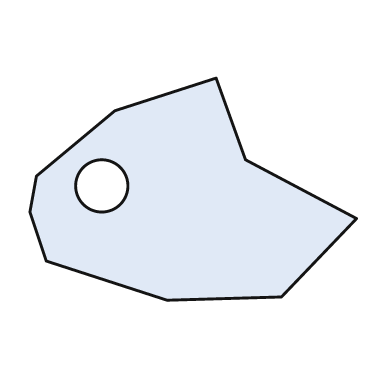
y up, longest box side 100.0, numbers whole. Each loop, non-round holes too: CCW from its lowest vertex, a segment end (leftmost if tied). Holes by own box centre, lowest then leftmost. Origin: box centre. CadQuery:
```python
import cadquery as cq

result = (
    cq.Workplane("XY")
    .moveTo(-8.0, -34.0)
    .lineTo(27.0, -33.0)
    .lineTo(50.0, -9.0)
    .lineTo(16.0, 9.0)
    .lineTo(7.0, 34.0)
    .lineTo(-24.0, 24.0)
    .lineTo(-48.0, 4.0)
    .lineTo(-50.0, -7.0)
    .lineTo(-45.0, -22.0)
    .close()
    .moveTo(-28.0, 1.0)
    .circle(8.0)
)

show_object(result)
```